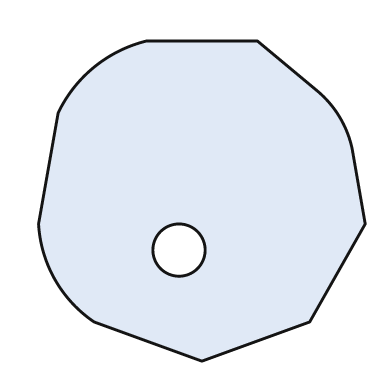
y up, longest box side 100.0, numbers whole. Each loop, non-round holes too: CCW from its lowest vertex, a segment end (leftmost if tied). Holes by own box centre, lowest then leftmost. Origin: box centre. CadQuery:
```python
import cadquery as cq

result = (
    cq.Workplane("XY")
    .moveTo(0.0, -49.0)
    .lineTo(33.0, -37.0)
    .lineTo(50.0, -7.0)
    .lineTo(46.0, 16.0)
    .threePointArc((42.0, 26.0), (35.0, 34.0))
    .lineTo(17.0, 49.0)
    .lineTo(-17.0, 49.0)
    .threePointArc((-33.0, 41.0), (-44.0, 27.0))
    .lineTo(-50.0, -7.0)
    .threePointArc((-45.0, -24.0), (-33.0, -37.0))
    .close()
    .moveTo(-7.0, -15.0)
    .circle(8.0)
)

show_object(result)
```